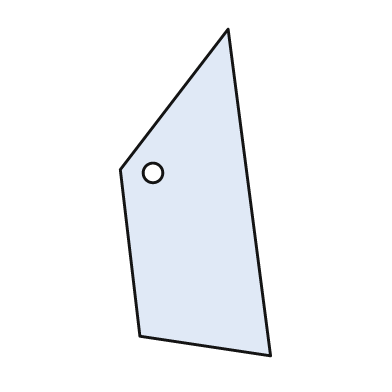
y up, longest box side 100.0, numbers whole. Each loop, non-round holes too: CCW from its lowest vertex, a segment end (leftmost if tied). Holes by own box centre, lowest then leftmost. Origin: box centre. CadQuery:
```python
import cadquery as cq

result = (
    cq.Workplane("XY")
    .moveTo(23.0, -50.0)
    .lineTo(10.0, 50.0)
    .lineTo(-23.0, 7.0)
    .lineTo(-17.0, -44.0)
    .close()
    .moveTo(-13.0, 6.0)
    .circle(3.0)
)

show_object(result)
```